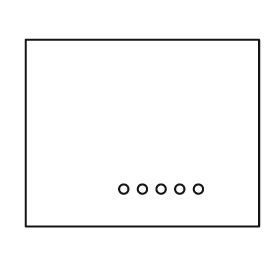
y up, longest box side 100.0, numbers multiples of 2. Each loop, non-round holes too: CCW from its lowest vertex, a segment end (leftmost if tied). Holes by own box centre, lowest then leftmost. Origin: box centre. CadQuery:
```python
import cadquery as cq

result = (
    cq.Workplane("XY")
    .moveTo(-50.0, -40.0)
    .lineTo(50.0, -40.0)
    .lineTo(50.0, 40.0)
    .lineTo(-50.0, 40.0)
    .close()
    .moveTo(-8.0, -24.0)
    .circle(2.0)
    .moveTo(0.0, -24.0)
    .circle(2.0)
    .moveTo(8.0, -24.0)
    .circle(2.0)
    .moveTo(16.0, -24.0)
    .circle(2.0)
    .moveTo(24.0, -24.0)
    .circle(2.0)
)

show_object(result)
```